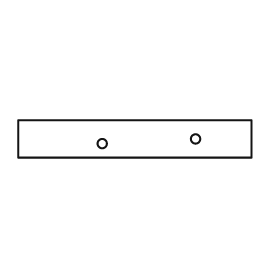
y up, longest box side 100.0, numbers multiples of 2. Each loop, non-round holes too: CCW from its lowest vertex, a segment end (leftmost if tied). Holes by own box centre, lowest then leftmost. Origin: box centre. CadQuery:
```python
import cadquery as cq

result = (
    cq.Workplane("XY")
    .moveTo(-50.0, -8.0)
    .lineTo(50.0, -8.0)
    .lineTo(50.0, 8.0)
    .lineTo(-50.0, 8.0)
    .close()
    .moveTo(-14.0, -2.0)
    .circle(2.0)
    .moveTo(26.0, 0.0)
    .circle(2.0)
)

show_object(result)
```